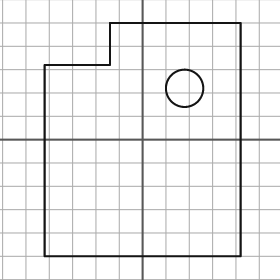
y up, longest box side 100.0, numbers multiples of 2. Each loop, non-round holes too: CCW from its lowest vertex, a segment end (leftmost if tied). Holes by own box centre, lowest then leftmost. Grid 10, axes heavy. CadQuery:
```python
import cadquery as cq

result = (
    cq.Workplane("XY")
    .moveTo(-42.0, -50.0)
    .lineTo(42.0, -50.0)
    .lineTo(42.0, 50.0)
    .lineTo(-14.0, 50.0)
    .lineTo(-14.0, 32.0)
    .lineTo(-42.0, 32.0)
    .close()
    .moveTo(18.0, 22.0)
    .circle(8.0)
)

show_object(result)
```